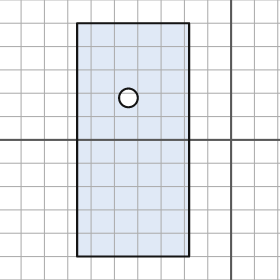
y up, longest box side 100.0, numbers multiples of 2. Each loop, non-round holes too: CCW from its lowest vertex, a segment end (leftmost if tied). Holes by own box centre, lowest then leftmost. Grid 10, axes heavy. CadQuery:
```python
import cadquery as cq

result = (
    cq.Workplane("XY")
    .moveTo(-66.0, -50.0)
    .lineTo(-18.0, -50.0)
    .lineTo(-18.0, 50.0)
    .lineTo(-66.0, 50.0)
    .close()
    .moveTo(-44.0, 18.0)
    .circle(4.0)
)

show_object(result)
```